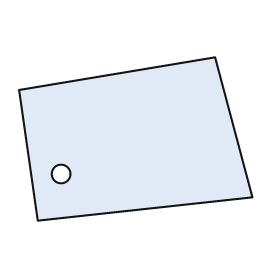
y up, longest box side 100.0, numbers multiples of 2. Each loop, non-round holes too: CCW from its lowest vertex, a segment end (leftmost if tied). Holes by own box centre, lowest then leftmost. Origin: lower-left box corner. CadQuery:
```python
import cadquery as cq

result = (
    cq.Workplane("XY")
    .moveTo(8.0, 0.0)
    .lineTo(100.0, 10.0)
    .lineTo(84.0, 70.0)
    .lineTo(0.0, 56.0)
    .close()
    .moveTo(18.0, 20.0)
    .circle(4.0)
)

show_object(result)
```